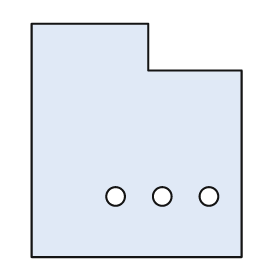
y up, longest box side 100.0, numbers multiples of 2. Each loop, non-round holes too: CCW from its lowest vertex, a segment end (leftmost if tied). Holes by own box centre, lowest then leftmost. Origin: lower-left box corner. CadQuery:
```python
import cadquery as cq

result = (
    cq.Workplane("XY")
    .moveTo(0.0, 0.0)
    .lineTo(90.0, 0.0)
    .lineTo(90.0, 80.0)
    .lineTo(50.0, 80.0)
    .lineTo(50.0, 100.0)
    .lineTo(0.0, 100.0)
    .close()
    .moveTo(36.0, 26.0)
    .circle(4.0)
    .moveTo(56.0, 26.0)
    .circle(4.0)
    .moveTo(76.0, 26.0)
    .circle(4.0)
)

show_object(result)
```